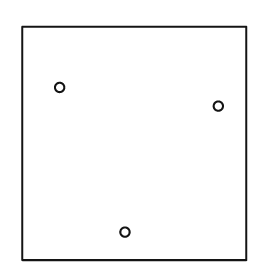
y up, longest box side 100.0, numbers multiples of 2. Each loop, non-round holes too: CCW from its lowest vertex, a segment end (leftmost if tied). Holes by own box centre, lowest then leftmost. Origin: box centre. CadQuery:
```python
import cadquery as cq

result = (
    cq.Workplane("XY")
    .moveTo(-48.0, -50.0)
    .lineTo(48.0, -50.0)
    .lineTo(48.0, 50.0)
    .lineTo(-48.0, 50.0)
    .close()
    .moveTo(-4.0, -38.0)
    .circle(2.0)
    .moveTo(36.0, 16.0)
    .circle(2.0)
    .moveTo(-32.0, 24.0)
    .circle(2.0)
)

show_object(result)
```